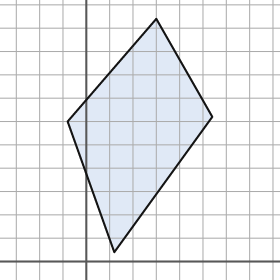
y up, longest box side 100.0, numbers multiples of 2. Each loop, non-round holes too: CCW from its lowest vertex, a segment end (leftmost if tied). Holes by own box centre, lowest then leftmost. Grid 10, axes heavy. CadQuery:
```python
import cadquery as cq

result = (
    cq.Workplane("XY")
    .moveTo(12.0, 4.0)
    .lineTo(54.0, 62.0)
    .lineTo(30.0, 104.0)
    .lineTo(-8.0, 60.0)
    .close()
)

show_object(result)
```